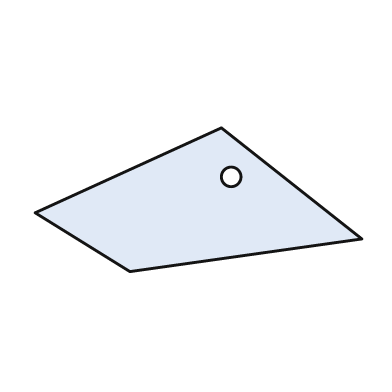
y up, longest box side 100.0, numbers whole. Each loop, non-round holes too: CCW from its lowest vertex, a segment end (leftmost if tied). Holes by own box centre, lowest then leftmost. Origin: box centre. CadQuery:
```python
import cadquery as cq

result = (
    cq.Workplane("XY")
    .moveTo(-21.0, -22.0)
    .lineTo(50.0, -12.0)
    .lineTo(7.0, 22.0)
    .lineTo(-50.0, -4.0)
    .close()
    .moveTo(10.0, 7.0)
    .circle(3.0)
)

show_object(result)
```